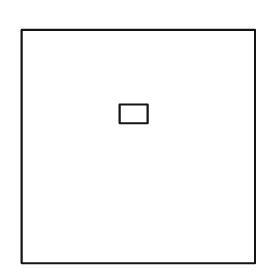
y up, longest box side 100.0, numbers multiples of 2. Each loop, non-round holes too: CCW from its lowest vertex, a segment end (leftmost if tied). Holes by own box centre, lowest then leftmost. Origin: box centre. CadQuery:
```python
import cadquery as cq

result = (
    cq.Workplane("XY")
    .moveTo(-50.0, -50.0)
    .lineTo(50.0, -50.0)
    .lineTo(50.0, 50.0)
    .lineTo(-50.0, 50.0)
    .close()
    .moveTo(-8.0, 10.0)
    .lineTo(4.0, 10.0)
    .lineTo(4.0, 18.0)
    .lineTo(-8.0, 18.0)
    .close()
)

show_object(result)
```